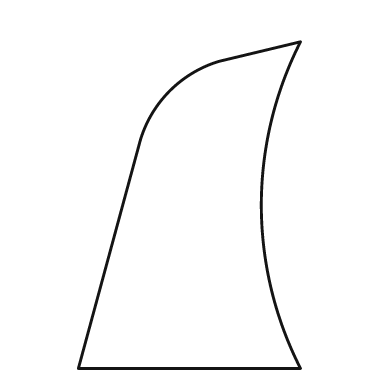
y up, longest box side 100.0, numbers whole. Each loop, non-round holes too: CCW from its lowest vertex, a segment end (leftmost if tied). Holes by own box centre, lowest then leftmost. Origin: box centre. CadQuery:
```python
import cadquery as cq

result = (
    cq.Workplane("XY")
    .moveTo(-34.0, -50.0)
    .lineTo(34.0, -50.0)
    .threePointArc((22.0, 0.0), (34.0, 50.0))
    .lineTo(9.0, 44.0)
    .threePointArc((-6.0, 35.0), (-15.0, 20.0))
    .close()
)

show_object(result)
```